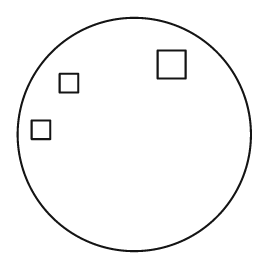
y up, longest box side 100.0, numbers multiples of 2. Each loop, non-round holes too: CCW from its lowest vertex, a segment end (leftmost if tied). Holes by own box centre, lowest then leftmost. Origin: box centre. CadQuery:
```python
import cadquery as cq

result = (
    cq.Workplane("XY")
    .moveTo(0.0, 0.0)
    .circle(50.0)
    .moveTo(-44.0, -2.0)
    .lineTo(-36.0, -2.0)
    .lineTo(-36.0, 6.0)
    .lineTo(-44.0, 6.0)
    .close()
    .moveTo(-32.0, 18.0)
    .lineTo(-24.0, 18.0)
    .lineTo(-24.0, 26.0)
    .lineTo(-32.0, 26.0)
    .close()
    .moveTo(10.0, 24.0)
    .lineTo(22.0, 24.0)
    .lineTo(22.0, 36.0)
    .lineTo(10.0, 36.0)
    .close()
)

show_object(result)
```